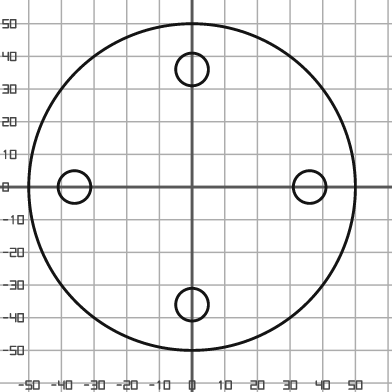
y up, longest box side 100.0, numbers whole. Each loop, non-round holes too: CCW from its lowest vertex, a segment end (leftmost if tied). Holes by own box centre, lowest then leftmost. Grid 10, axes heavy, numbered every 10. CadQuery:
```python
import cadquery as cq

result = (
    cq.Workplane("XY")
    .moveTo(0.0, 0.0)
    .circle(50.0)
    .moveTo(0.0, -36.0)
    .circle(5.0)
    .moveTo(-36.0, 0.0)
    .circle(5.0)
    .moveTo(36.0, 0.0)
    .circle(5.0)
    .moveTo(0.0, 36.0)
    .circle(5.0)
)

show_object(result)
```